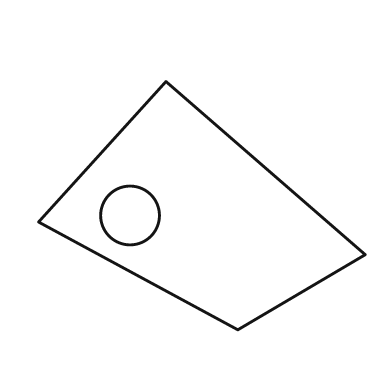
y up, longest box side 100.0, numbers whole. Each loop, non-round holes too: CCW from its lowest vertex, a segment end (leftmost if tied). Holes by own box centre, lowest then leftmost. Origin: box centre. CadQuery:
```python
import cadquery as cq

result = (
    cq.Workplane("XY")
    .moveTo(11.0, -38.0)
    .lineTo(50.0, -15.0)
    .lineTo(-11.0, 38.0)
    .lineTo(-50.0, -5.0)
    .close()
    .moveTo(-22.0, -3.0)
    .circle(9.0)
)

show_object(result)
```